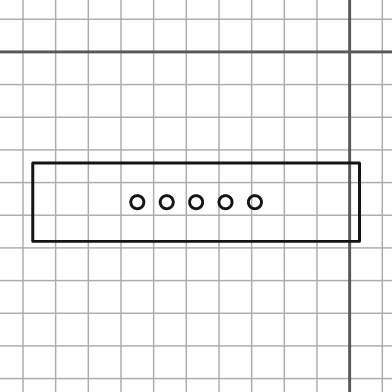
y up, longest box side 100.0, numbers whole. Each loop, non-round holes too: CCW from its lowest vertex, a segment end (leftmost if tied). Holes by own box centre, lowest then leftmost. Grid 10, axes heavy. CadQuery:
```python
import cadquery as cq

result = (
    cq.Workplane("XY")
    .moveTo(-97.0, -58.0)
    .lineTo(3.0, -58.0)
    .lineTo(3.0, -34.0)
    .lineTo(-97.0, -34.0)
    .close()
    .moveTo(-65.0, -46.0)
    .circle(2.0)
    .moveTo(-56.0, -46.0)
    .circle(2.0)
    .moveTo(-47.0, -46.0)
    .circle(2.0)
    .moveTo(-38.0, -46.0)
    .circle(2.0)
    .moveTo(-29.0, -46.0)
    .circle(2.0)
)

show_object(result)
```